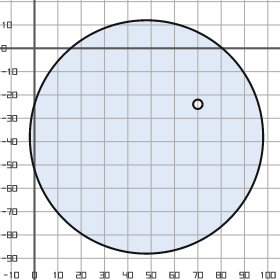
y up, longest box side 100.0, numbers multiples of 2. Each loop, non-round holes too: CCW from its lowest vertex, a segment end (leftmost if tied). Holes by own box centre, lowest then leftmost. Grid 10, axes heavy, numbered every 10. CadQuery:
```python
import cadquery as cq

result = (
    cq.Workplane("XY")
    .moveTo(48.0, -38.0)
    .circle(50.0)
    .moveTo(70.0, -24.0)
    .circle(2.0)
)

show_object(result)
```